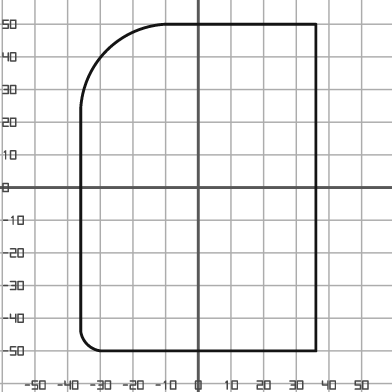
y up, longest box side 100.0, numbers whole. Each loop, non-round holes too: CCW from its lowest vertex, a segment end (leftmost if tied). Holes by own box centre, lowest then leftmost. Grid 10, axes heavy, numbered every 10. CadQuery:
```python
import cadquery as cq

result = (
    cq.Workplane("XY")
    .moveTo(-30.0, -50.0)
    .lineTo(36.0, -50.0)
    .lineTo(36.0, 50.0)
    .lineTo(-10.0, 50.0)
    .threePointArc((-28.0, 42.0), (-36.0, 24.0))
    .lineTo(-36.0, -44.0)
    .threePointArc((-34.0, -48.0), (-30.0, -50.0))
    .close()
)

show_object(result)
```